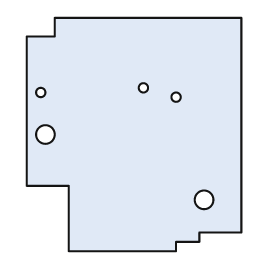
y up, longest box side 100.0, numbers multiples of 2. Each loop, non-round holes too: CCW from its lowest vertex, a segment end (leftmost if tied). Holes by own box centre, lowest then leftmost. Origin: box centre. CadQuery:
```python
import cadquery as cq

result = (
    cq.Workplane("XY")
    .moveTo(-28.0, -50.0)
    .lineTo(18.0, -50.0)
    .lineTo(18.0, -46.0)
    .lineTo(28.0, -46.0)
    .lineTo(28.0, -42.0)
    .lineTo(46.0, -42.0)
    .lineTo(46.0, 50.0)
    .lineTo(-34.0, 50.0)
    .lineTo(-34.0, 42.0)
    .lineTo(-46.0, 42.0)
    .lineTo(-46.0, -22.0)
    .lineTo(-28.0, -22.0)
    .close()
    .moveTo(30.0, -28.0)
    .circle(4.0)
    .moveTo(-38.0, 0.0)
    .circle(4.0)
    .moveTo(18.0, 16.0)
    .circle(2.0)
    .moveTo(-40.0, 18.0)
    .circle(2.0)
    .moveTo(4.0, 20.0)
    .circle(2.0)
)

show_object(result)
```